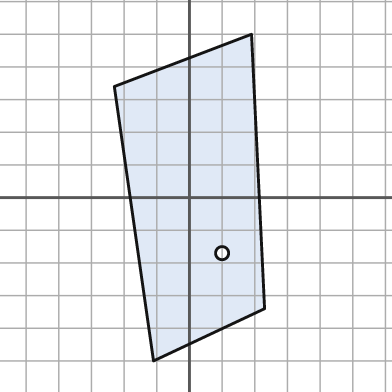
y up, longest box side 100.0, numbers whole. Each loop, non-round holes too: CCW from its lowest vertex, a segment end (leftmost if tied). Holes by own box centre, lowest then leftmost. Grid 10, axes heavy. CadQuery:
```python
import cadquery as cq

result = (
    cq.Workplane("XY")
    .moveTo(-11.0, -50.0)
    .lineTo(23.0, -34.0)
    .lineTo(19.0, 50.0)
    .lineTo(-23.0, 34.0)
    .close()
    .moveTo(10.0, -17.0)
    .circle(2.0)
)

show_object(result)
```